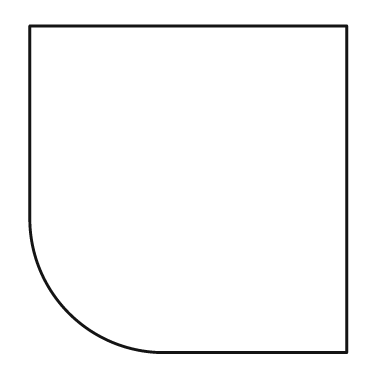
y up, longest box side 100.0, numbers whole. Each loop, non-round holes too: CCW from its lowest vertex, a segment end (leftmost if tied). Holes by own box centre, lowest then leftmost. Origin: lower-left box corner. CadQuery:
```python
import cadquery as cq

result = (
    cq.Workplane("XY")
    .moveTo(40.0, 0.0)
    .lineTo(97.0, 0.0)
    .lineTo(97.0, 100.0)
    .lineTo(0.0, 100.0)
    .lineTo(0.0, 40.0)
    .threePointArc((12.0, 12.0), (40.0, 0.0))
    .close()
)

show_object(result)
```